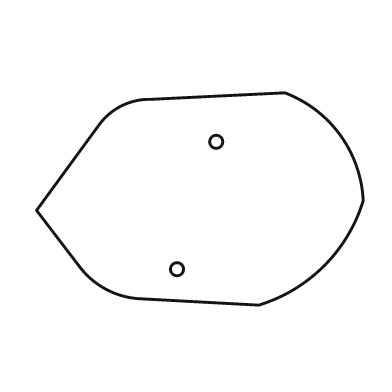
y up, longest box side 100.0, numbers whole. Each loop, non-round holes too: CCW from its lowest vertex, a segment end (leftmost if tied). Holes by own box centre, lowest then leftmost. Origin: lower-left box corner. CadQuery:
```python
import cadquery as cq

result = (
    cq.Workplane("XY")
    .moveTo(68.0, 0.0)
    .threePointArc((88.0, 12.0), (100.0, 32.0))
    .threePointArc((93.0, 52.0), (76.0, 65.0))
    .lineTo(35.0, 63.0)
    .threePointArc((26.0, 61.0), (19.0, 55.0))
    .lineTo(0.0, 29.0)
    .lineTo(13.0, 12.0)
    .threePointArc((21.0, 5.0), (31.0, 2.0))
    .close()
    .moveTo(43.0, 11.0)
    .circle(2.0)
    .moveTo(55.0, 50.0)
    .circle(2.0)
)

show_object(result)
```